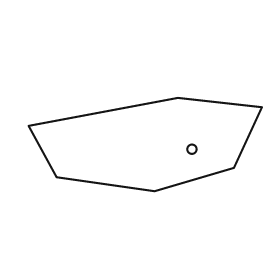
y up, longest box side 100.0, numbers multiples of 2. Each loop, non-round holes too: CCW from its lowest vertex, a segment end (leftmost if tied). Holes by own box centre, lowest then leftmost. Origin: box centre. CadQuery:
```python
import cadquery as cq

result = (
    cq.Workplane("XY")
    .moveTo(4.0, -20.0)
    .lineTo(38.0, -10.0)
    .lineTo(50.0, 16.0)
    .lineTo(14.0, 20.0)
    .lineTo(-50.0, 8.0)
    .lineTo(-38.0, -14.0)
    .close()
    .moveTo(20.0, -2.0)
    .circle(2.0)
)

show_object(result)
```